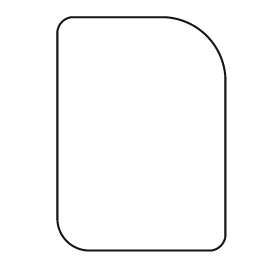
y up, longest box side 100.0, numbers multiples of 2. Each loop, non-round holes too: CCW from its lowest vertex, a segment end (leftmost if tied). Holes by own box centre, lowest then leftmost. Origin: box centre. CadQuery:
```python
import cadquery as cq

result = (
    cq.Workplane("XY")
    .moveTo(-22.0, -50.0)
    .lineTo(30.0, -50.0)
    .threePointArc((34.0, -48.0), (36.0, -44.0))
    .lineTo(36.0, 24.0)
    .threePointArc((28.0, 42.0), (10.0, 50.0))
    .lineTo(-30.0, 50.0)
    .threePointArc((-34.0, 48.0), (-36.0, 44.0))
    .lineTo(-36.0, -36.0)
    .threePointArc((-32.0, -46.0), (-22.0, -50.0))
    .close()
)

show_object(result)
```